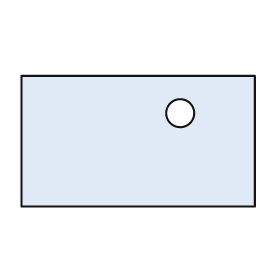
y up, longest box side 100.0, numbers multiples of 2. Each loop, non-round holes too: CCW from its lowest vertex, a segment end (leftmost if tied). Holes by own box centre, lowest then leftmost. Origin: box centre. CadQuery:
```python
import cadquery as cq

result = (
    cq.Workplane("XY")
    .moveTo(-50.0, -28.0)
    .lineTo(50.0, -28.0)
    .lineTo(50.0, 28.0)
    .lineTo(-50.0, 28.0)
    .close()
    .moveTo(18.0, 12.0)
    .circle(6.0)
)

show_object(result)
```